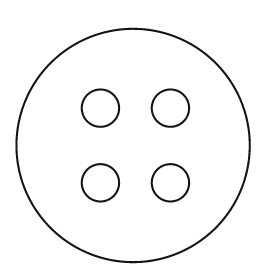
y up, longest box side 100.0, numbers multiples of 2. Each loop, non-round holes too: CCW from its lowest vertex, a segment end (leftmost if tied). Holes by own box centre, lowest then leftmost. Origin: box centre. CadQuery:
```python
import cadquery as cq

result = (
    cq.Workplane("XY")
    .moveTo(0.0, 0.0)
    .circle(50.0)
    .moveTo(-14.0, -16.0)
    .circle(8.0)
    .moveTo(16.0, -16.0)
    .circle(8.0)
    .moveTo(-14.0, 16.0)
    .circle(8.0)
    .moveTo(16.0, 16.0)
    .circle(8.0)
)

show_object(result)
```